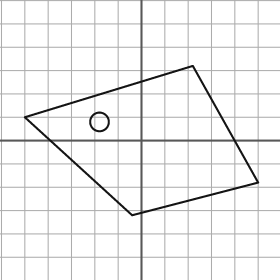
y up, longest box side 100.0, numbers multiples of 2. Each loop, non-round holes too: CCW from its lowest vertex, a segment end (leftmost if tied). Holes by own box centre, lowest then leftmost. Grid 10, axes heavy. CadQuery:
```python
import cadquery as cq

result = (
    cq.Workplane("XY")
    .moveTo(-4.0, -32.0)
    .lineTo(50.0, -18.0)
    .lineTo(22.0, 32.0)
    .lineTo(-50.0, 10.0)
    .close()
    .moveTo(-18.0, 8.0)
    .circle(4.0)
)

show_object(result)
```